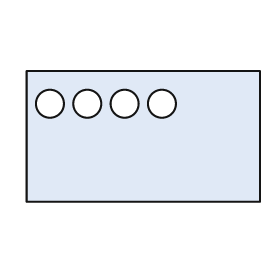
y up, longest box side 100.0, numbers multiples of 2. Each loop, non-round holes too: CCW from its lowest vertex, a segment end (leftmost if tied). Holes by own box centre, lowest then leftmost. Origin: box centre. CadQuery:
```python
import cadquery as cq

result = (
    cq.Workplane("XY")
    .moveTo(-50.0, -28.0)
    .lineTo(50.0, -28.0)
    .lineTo(50.0, 28.0)
    .lineTo(-50.0, 28.0)
    .close()
    .moveTo(-40.0, 14.0)
    .circle(6.0)
    .moveTo(-24.0, 14.0)
    .circle(6.0)
    .moveTo(-8.0, 14.0)
    .circle(6.0)
    .moveTo(8.0, 14.0)
    .circle(6.0)
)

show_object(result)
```